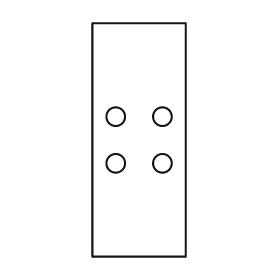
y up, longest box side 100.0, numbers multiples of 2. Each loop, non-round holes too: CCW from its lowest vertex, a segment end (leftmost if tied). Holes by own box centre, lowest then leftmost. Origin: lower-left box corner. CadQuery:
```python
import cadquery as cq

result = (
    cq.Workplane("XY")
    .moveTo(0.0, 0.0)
    .lineTo(40.0, 0.0)
    .lineTo(40.0, 100.0)
    .lineTo(0.0, 100.0)
    .close()
    .moveTo(10.0, 40.0)
    .circle(4.0)
    .moveTo(30.0, 40.0)
    .circle(4.0)
    .moveTo(10.0, 60.0)
    .circle(4.0)
    .moveTo(30.0, 60.0)
    .circle(4.0)
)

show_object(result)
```